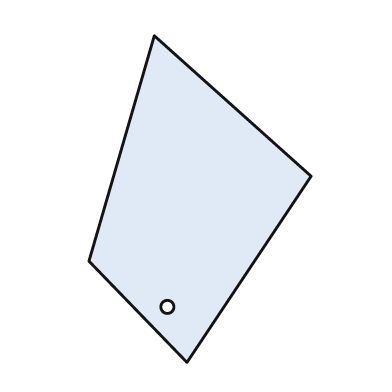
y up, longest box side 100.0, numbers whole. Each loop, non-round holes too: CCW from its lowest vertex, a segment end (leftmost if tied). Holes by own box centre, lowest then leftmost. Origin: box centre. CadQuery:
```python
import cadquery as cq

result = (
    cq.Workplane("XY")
    .moveTo(-4.0, -50.0)
    .lineTo(34.0, 7.0)
    .lineTo(-14.0, 50.0)
    .lineTo(-34.0, -19.0)
    .close()
    .moveTo(-10.0, -33.0)
    .circle(2.0)
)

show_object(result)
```